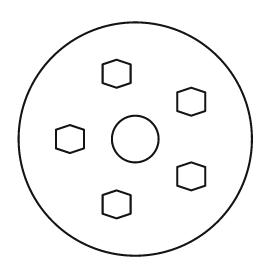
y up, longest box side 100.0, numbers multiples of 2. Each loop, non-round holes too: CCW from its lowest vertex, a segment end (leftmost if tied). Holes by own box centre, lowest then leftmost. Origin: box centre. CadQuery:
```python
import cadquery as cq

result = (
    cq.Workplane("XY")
    .moveTo(0.0, 0.0)
    .circle(50.0)
    .moveTo(-8.0, -34.0)
    .lineTo(-2.0, -32.0)
    .lineTo(-2.0, -24.0)
    .lineTo(-8.0, -22.0)
    .lineTo(-14.0, -24.0)
    .lineTo(-14.0, -32.0)
    .close()
    .moveTo(24.0, -22.0)
    .lineTo(30.0, -20.0)
    .lineTo(30.0, -12.0)
    .lineTo(24.0, -10.0)
    .lineTo(18.0, -12.0)
    .lineTo(18.0, -20.0)
    .close()
    .moveTo(-28.0, -6.0)
    .lineTo(-22.0, -4.0)
    .lineTo(-22.0, 4.0)
    .lineTo(-28.0, 6.0)
    .lineTo(-34.0, 4.0)
    .lineTo(-34.0, -4.0)
    .close()
    .moveTo(0.0, 0.0)
    .circle(10.0)
    .moveTo(24.0, 10.0)
    .lineTo(30.0, 12.0)
    .lineTo(30.0, 20.0)
    .lineTo(24.0, 22.0)
    .lineTo(18.0, 20.0)
    .lineTo(18.0, 12.0)
    .close()
    .moveTo(-8.0, 22.0)
    .lineTo(-2.0, 24.0)
    .lineTo(-2.0, 32.0)
    .lineTo(-8.0, 34.0)
    .lineTo(-14.0, 32.0)
    .lineTo(-14.0, 24.0)
    .close()
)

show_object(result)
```